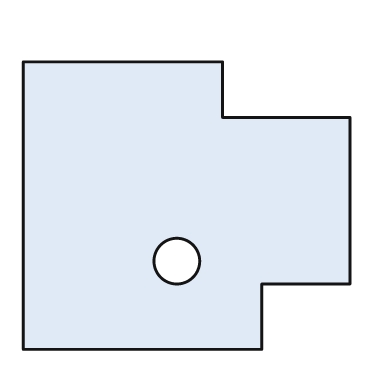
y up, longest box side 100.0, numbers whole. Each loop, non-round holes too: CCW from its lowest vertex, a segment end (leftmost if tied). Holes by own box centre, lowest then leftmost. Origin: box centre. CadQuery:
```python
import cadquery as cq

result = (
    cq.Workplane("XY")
    .moveTo(-50.0, -44.0)
    .lineTo(23.0, -44.0)
    .lineTo(23.0, -24.0)
    .lineTo(50.0, -24.0)
    .lineTo(50.0, 27.0)
    .lineTo(11.0, 27.0)
    .lineTo(11.0, 44.0)
    .lineTo(-50.0, 44.0)
    .close()
    .moveTo(-3.0, -17.0)
    .circle(7.0)
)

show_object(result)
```